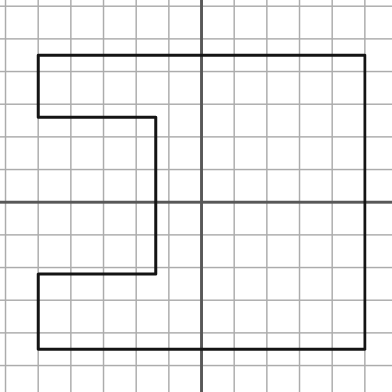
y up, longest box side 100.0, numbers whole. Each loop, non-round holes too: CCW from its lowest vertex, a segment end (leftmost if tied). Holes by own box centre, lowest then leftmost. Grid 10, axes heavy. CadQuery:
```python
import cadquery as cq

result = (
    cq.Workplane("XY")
    .moveTo(-50.0, -45.0)
    .lineTo(50.0, -45.0)
    .lineTo(50.0, 45.0)
    .lineTo(-50.0, 45.0)
    .lineTo(-50.0, 26.0)
    .lineTo(-14.0, 26.0)
    .lineTo(-14.0, -22.0)
    .lineTo(-50.0, -22.0)
    .close()
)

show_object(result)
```